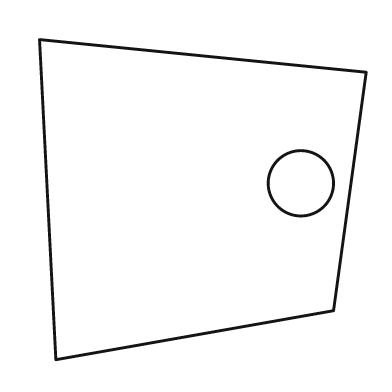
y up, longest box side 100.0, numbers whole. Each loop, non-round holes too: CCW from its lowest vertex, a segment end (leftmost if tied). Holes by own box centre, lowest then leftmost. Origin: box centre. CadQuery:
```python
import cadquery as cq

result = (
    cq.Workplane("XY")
    .moveTo(-45.0, -49.0)
    .lineTo(40.0, -34.0)
    .lineTo(50.0, 39.0)
    .lineTo(-50.0, 49.0)
    .close()
    .moveTo(30.0, 5.0)
    .circle(10.0)
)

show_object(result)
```